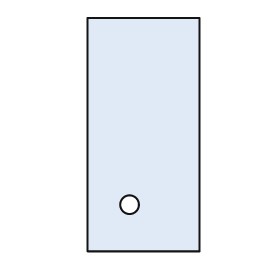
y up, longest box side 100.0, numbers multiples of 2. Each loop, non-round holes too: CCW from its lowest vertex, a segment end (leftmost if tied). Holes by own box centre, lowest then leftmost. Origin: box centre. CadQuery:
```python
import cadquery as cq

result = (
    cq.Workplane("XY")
    .moveTo(-24.0, -50.0)
    .lineTo(24.0, -50.0)
    .lineTo(24.0, 50.0)
    .lineTo(-24.0, 50.0)
    .close()
    .moveTo(-6.0, -30.0)
    .circle(4.0)
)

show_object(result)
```